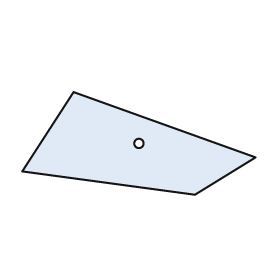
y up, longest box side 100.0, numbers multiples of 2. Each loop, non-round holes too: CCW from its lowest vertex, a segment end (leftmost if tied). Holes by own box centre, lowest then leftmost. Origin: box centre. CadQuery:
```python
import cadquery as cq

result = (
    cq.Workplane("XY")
    .moveTo(24.0, -22.0)
    .lineTo(50.0, -6.0)
    .lineTo(-28.0, 22.0)
    .lineTo(-50.0, -12.0)
    .close()
    .moveTo(0.0, 0.0)
    .circle(2.0)
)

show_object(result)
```